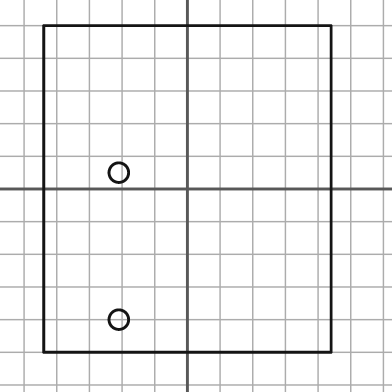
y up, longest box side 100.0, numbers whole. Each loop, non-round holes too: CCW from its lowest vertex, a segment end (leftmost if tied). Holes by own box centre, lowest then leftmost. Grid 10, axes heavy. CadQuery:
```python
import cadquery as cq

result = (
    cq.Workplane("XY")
    .moveTo(-44.0, -50.0)
    .lineTo(44.0, -50.0)
    .lineTo(44.0, 50.0)
    .lineTo(-44.0, 50.0)
    .close()
    .moveTo(-21.0, -40.0)
    .circle(3.0)
    .moveTo(-21.0, 5.0)
    .circle(3.0)
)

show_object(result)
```